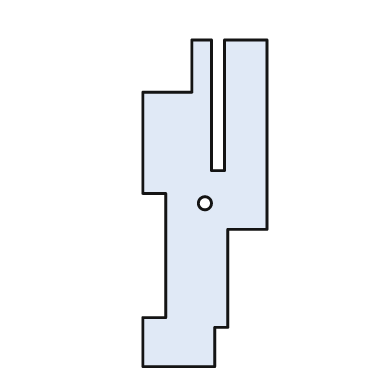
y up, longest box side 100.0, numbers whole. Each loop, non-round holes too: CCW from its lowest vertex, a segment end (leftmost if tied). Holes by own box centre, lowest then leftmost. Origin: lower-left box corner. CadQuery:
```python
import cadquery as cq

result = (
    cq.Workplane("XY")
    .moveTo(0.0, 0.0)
    .lineTo(22.0, 0.0)
    .lineTo(22.0, 12.0)
    .lineTo(26.0, 12.0)
    .lineTo(26.0, 42.0)
    .lineTo(38.0, 42.0)
    .lineTo(38.0, 100.0)
    .lineTo(25.0, 100.0)
    .lineTo(25.0, 60.0)
    .lineTo(21.0, 60.0)
    .lineTo(21.0, 100.0)
    .lineTo(15.0, 100.0)
    .lineTo(15.0, 84.0)
    .lineTo(0.0, 84.0)
    .lineTo(0.0, 53.0)
    .lineTo(7.0, 53.0)
    .lineTo(7.0, 15.0)
    .lineTo(0.0, 15.0)
    .close()
    .moveTo(19.0, 50.0)
    .circle(2.0)
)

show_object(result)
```